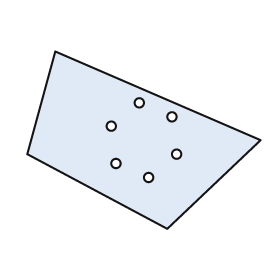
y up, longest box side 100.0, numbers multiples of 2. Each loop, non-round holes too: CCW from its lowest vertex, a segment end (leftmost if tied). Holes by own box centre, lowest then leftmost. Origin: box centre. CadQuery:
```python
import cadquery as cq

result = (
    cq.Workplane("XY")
    .moveTo(10.0, -38.0)
    .lineTo(50.0, 0.0)
    .lineTo(-38.0, 38.0)
    .lineTo(-50.0, -6.0)
    .close()
    .moveTo(2.0, -16.0)
    .circle(2.0)
    .moveTo(-12.0, -10.0)
    .circle(2.0)
    .moveTo(14.0, -6.0)
    .circle(2.0)
    .moveTo(-14.0, 6.0)
    .circle(2.0)
    .moveTo(12.0, 10.0)
    .circle(2.0)
    .moveTo(-2.0, 16.0)
    .circle(2.0)
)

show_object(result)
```